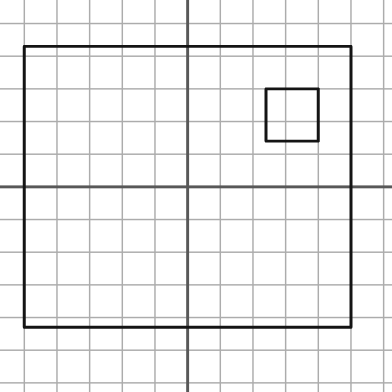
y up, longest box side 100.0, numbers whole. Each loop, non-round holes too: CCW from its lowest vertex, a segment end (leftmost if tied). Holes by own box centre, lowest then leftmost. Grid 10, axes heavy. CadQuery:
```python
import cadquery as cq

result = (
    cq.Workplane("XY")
    .moveTo(-50.0, -43.0)
    .lineTo(50.0, -43.0)
    .lineTo(50.0, 43.0)
    .lineTo(-50.0, 43.0)
    .close()
    .moveTo(24.0, 14.0)
    .lineTo(40.0, 14.0)
    .lineTo(40.0, 30.0)
    .lineTo(24.0, 30.0)
    .close()
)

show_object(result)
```